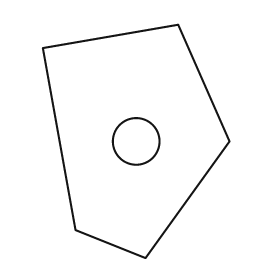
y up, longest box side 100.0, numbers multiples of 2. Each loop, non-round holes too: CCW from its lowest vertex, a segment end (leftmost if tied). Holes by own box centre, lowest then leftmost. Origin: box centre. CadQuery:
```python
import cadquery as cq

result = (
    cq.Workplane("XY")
    .moveTo(4.0, -50.0)
    .lineTo(40.0, 0.0)
    .lineTo(18.0, 50.0)
    .lineTo(-40.0, 40.0)
    .lineTo(-26.0, -38.0)
    .close()
    .moveTo(0.0, 0.0)
    .circle(10.0)
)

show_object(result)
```